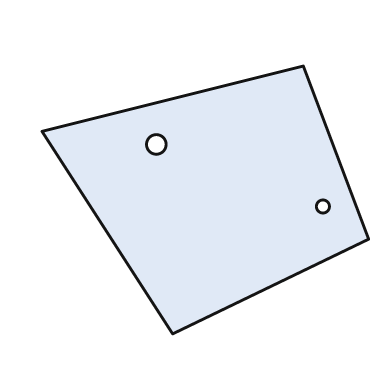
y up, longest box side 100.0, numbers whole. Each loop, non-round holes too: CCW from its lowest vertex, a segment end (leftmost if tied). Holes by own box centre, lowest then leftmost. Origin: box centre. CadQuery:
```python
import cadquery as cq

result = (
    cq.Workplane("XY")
    .moveTo(-10.0, -41.0)
    .lineTo(50.0, -12.0)
    .lineTo(30.0, 41.0)
    .lineTo(-50.0, 21.0)
    .close()
    .moveTo(36.0, -2.0)
    .circle(2.0)
    .moveTo(-15.0, 17.0)
    .circle(3.0)
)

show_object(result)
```